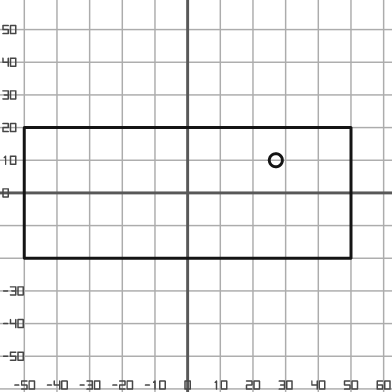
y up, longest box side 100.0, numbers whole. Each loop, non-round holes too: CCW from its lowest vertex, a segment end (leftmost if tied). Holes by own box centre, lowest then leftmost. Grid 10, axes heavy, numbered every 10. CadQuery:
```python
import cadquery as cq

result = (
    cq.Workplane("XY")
    .moveTo(-50.0, -20.0)
    .lineTo(50.0, -20.0)
    .lineTo(50.0, 20.0)
    .lineTo(-50.0, 20.0)
    .close()
    .moveTo(27.0, 10.0)
    .circle(2.0)
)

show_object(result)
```